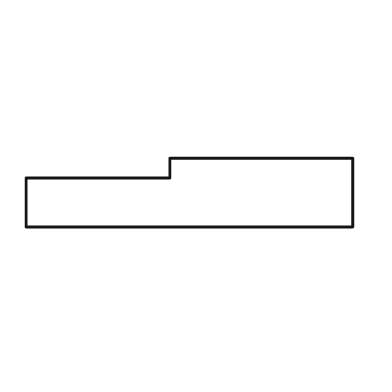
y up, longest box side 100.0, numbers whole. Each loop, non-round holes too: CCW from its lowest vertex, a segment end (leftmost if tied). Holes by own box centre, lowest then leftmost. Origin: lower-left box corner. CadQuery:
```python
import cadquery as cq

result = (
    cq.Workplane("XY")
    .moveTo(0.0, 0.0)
    .lineTo(100.0, 0.0)
    .lineTo(100.0, 21.0)
    .lineTo(44.0, 21.0)
    .lineTo(44.0, 15.0)
    .lineTo(0.0, 15.0)
    .close()
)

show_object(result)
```